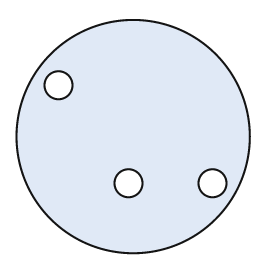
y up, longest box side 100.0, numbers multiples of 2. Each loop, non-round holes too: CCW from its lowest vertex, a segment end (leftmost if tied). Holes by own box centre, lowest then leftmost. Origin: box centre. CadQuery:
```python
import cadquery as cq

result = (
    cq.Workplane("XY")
    .moveTo(0.0, 0.0)
    .circle(50.0)
    .moveTo(-2.0, -20.0)
    .circle(6.0)
    .moveTo(34.0, -20.0)
    .circle(6.0)
    .moveTo(-32.0, 22.0)
    .circle(6.0)
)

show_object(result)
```